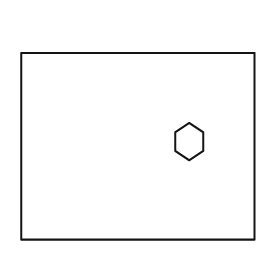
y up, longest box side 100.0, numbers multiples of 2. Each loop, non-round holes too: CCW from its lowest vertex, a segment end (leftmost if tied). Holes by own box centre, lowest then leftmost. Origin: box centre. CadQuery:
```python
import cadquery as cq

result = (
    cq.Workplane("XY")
    .moveTo(-50.0, -40.0)
    .lineTo(50.0, -40.0)
    .lineTo(50.0, 40.0)
    .lineTo(-50.0, 40.0)
    .close()
    .moveTo(22.0, -6.0)
    .lineTo(28.0, -2.0)
    .lineTo(28.0, 6.0)
    .lineTo(22.0, 10.0)
    .lineTo(16.0, 6.0)
    .lineTo(16.0, -2.0)
    .close()
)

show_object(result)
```